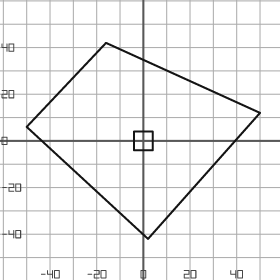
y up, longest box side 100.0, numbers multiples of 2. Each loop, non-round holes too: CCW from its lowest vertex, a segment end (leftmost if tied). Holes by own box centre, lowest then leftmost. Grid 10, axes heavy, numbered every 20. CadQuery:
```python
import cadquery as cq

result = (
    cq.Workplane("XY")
    .moveTo(2.0, -42.0)
    .lineTo(50.0, 12.0)
    .lineTo(-16.0, 42.0)
    .lineTo(-50.0, 6.0)
    .close()
    .moveTo(-4.0, -4.0)
    .lineTo(4.0, -4.0)
    .lineTo(4.0, 4.0)
    .lineTo(-4.0, 4.0)
    .close()
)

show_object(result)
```